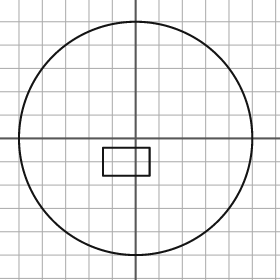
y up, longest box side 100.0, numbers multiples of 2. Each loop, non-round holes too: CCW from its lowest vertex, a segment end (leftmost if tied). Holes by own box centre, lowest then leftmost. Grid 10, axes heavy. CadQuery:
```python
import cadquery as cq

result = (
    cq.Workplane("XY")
    .moveTo(0.0, 0.0)
    .circle(50.0)
    .moveTo(-14.0, -16.0)
    .lineTo(6.0, -16.0)
    .lineTo(6.0, -4.0)
    .lineTo(-14.0, -4.0)
    .close()
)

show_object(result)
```